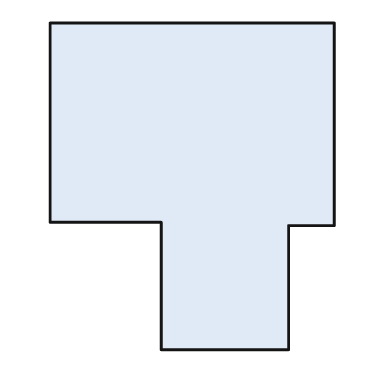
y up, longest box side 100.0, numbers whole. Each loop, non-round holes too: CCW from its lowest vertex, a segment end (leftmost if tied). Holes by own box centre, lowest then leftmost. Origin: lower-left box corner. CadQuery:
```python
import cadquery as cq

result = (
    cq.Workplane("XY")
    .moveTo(34.0, 0.0)
    .lineTo(73.0, 0.0)
    .lineTo(73.0, 38.0)
    .lineTo(87.0, 38.0)
    .lineTo(87.0, 100.0)
    .lineTo(0.0, 100.0)
    .lineTo(0.0, 39.0)
    .lineTo(34.0, 39.0)
    .close()
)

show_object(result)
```